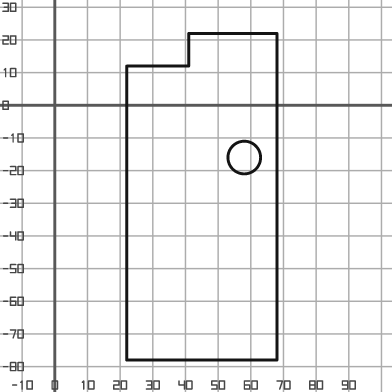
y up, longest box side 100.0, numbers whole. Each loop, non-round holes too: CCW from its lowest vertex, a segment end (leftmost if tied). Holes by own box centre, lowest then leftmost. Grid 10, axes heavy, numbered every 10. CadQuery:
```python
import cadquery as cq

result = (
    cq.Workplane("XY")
    .moveTo(22.0, -78.0)
    .lineTo(68.0, -78.0)
    .lineTo(68.0, 22.0)
    .lineTo(41.0, 22.0)
    .lineTo(41.0, 12.0)
    .lineTo(22.0, 12.0)
    .close()
    .moveTo(58.0, -16.0)
    .circle(5.0)
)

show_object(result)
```